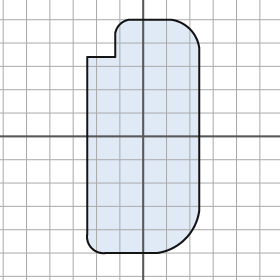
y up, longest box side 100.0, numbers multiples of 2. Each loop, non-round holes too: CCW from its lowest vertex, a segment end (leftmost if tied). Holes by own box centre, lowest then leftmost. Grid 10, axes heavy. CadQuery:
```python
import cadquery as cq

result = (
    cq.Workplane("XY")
    .moveTo(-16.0, -50.0)
    .lineTo(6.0, -50.0)
    .threePointArc((18.0, -44.0), (24.0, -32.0))
    .lineTo(24.0, 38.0)
    .threePointArc((20.0, 46.0), (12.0, 50.0))
    .lineTo(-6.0, 50.0)
    .threePointArc((-10.0, 48.0), (-12.0, 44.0))
    .lineTo(-12.0, 34.0)
    .lineTo(-24.0, 34.0)
    .lineTo(-24.0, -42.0)
    .threePointArc((-22.0, -48.0), (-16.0, -50.0))
    .close()
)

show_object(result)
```